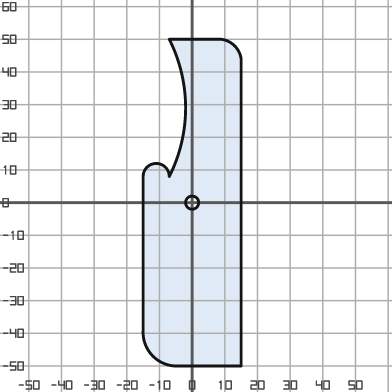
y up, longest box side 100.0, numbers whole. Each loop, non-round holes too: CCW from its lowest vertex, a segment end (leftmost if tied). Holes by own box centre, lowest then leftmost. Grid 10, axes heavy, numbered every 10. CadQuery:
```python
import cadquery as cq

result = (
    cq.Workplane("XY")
    .moveTo(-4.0, -50.0)
    .lineTo(15.0, -50.0)
    .lineTo(15.0, 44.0)
    .threePointArc((13.0, 48.0), (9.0, 50.0))
    .lineTo(-7.0, 50.0)
    .threePointArc((-2.0, 29.0), (-7.0, 8.0))
    .threePointArc((-11.0, 12.0), (-15.0, 8.0))
    .lineTo(-15.0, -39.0)
    .threePointArc((-12.0, -47.0), (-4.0, -50.0))
    .close()
    .moveTo(0.0, 0.0)
    .circle(2.0)
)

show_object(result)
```